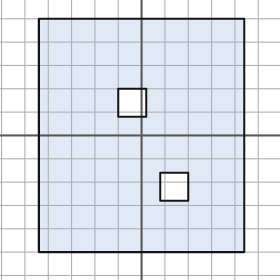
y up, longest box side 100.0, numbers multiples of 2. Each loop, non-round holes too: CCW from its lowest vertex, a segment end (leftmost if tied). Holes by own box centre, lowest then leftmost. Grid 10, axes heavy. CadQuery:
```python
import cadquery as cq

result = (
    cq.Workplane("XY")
    .moveTo(-44.0, -50.0)
    .lineTo(44.0, -50.0)
    .lineTo(44.0, 50.0)
    .lineTo(-44.0, 50.0)
    .close()
    .moveTo(8.0, -28.0)
    .lineTo(20.0, -28.0)
    .lineTo(20.0, -16.0)
    .lineTo(8.0, -16.0)
    .close()
    .moveTo(-10.0, 8.0)
    .lineTo(2.0, 8.0)
    .lineTo(2.0, 20.0)
    .lineTo(-10.0, 20.0)
    .close()
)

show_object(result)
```